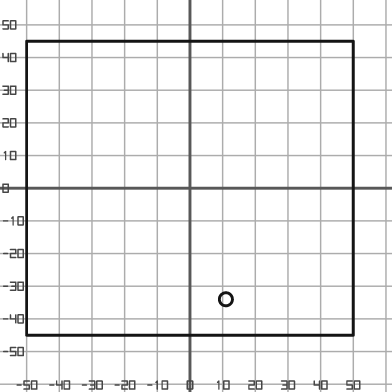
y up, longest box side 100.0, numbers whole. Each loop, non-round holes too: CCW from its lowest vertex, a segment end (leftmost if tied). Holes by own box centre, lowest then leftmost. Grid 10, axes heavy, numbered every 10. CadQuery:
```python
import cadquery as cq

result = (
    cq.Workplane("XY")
    .moveTo(-50.0, -45.0)
    .lineTo(50.0, -45.0)
    .lineTo(50.0, 45.0)
    .lineTo(-50.0, 45.0)
    .close()
    .moveTo(11.0, -34.0)
    .circle(2.0)
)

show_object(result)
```